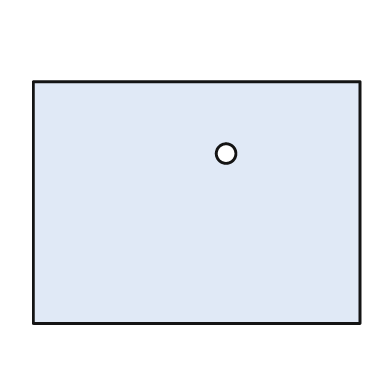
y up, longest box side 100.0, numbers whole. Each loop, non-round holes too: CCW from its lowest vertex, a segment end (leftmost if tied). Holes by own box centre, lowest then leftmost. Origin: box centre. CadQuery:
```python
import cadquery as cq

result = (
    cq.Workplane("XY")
    .moveTo(-50.0, -37.0)
    .lineTo(50.0, -37.0)
    .lineTo(50.0, 37.0)
    .lineTo(-50.0, 37.0)
    .close()
    .moveTo(9.0, 15.0)
    .circle(3.0)
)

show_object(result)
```